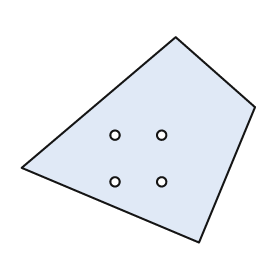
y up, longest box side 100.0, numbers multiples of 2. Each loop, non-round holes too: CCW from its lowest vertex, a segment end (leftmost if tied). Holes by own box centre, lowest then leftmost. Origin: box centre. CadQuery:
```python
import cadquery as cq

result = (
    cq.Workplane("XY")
    .moveTo(26.0, -44.0)
    .lineTo(50.0, 14.0)
    .lineTo(16.0, 44.0)
    .lineTo(-50.0, -12.0)
    .close()
    .moveTo(-10.0, -18.0)
    .circle(2.0)
    .moveTo(10.0, -18.0)
    .circle(2.0)
    .moveTo(-10.0, 2.0)
    .circle(2.0)
    .moveTo(10.0, 2.0)
    .circle(2.0)
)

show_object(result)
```